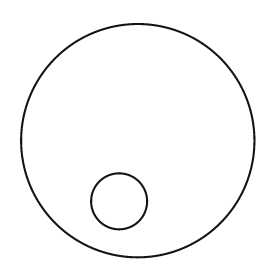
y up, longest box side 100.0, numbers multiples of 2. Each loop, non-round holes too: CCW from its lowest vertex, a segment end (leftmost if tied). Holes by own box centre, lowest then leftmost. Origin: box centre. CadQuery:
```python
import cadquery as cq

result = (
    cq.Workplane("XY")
    .moveTo(0.0, 0.0)
    .circle(50.0)
    .moveTo(-8.0, -26.0)
    .circle(12.0)
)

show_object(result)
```